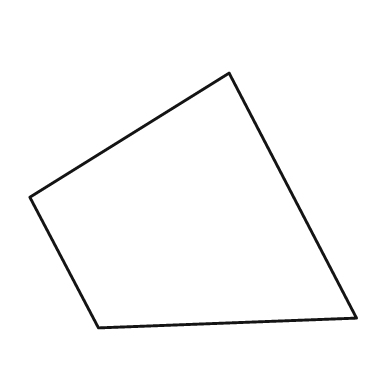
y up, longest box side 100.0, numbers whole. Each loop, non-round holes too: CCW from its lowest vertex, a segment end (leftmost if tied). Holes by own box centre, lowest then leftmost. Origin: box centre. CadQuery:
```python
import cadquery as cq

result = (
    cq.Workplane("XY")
    .moveTo(-29.0, -39.0)
    .lineTo(50.0, -36.0)
    .lineTo(11.0, 39.0)
    .lineTo(-50.0, 1.0)
    .close()
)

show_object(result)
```